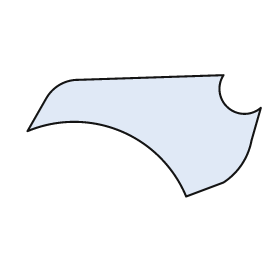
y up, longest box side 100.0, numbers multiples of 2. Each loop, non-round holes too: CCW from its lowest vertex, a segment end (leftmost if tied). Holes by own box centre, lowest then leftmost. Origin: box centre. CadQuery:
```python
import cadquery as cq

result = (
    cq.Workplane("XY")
    .moveTo(18.0, -26.0)
    .lineTo(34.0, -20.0)
    .threePointArc((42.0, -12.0), (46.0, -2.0))
    .lineTo(50.0, 12.0)
    .threePointArc((36.0, 12.0), (34.0, 26.0))
    .lineTo(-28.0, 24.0)
    .threePointArc((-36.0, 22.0), (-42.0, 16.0))
    .lineTo(-50.0, 2.0)
    .threePointArc((-10.0, 2.0), (18.0, -26.0))
    .close()
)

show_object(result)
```